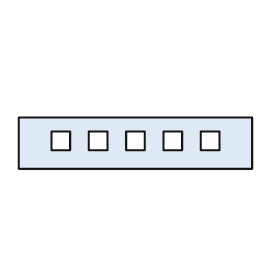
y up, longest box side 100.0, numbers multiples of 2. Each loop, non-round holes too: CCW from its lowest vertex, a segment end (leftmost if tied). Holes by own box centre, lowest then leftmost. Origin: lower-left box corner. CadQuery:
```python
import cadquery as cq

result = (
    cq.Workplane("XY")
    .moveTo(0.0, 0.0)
    .lineTo(100.0, 0.0)
    .lineTo(100.0, 22.0)
    .lineTo(0.0, 22.0)
    .close()
    .moveTo(14.0, 8.0)
    .lineTo(22.0, 8.0)
    .lineTo(22.0, 16.0)
    .lineTo(14.0, 16.0)
    .close()
    .moveTo(30.0, 8.0)
    .lineTo(38.0, 8.0)
    .lineTo(38.0, 16.0)
    .lineTo(30.0, 16.0)
    .close()
    .moveTo(46.0, 8.0)
    .lineTo(54.0, 8.0)
    .lineTo(54.0, 16.0)
    .lineTo(46.0, 16.0)
    .close()
    .moveTo(62.0, 8.0)
    .lineTo(70.0, 8.0)
    .lineTo(70.0, 16.0)
    .lineTo(62.0, 16.0)
    .close()
    .moveTo(78.0, 8.0)
    .lineTo(86.0, 8.0)
    .lineTo(86.0, 16.0)
    .lineTo(78.0, 16.0)
    .close()
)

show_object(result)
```